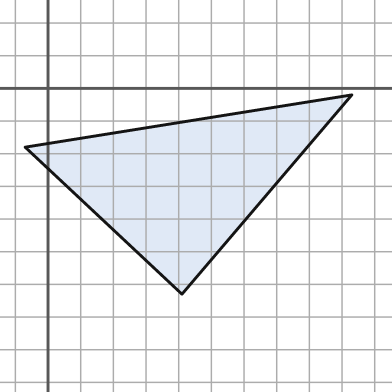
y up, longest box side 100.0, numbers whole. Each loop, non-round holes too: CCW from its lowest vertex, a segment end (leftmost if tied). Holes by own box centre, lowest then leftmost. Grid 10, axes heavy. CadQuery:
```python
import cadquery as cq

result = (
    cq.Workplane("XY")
    .moveTo(41.0, -63.0)
    .lineTo(93.0, -2.0)
    .lineTo(-7.0, -18.0)
    .close()
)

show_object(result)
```